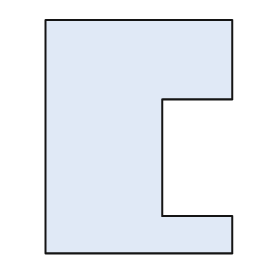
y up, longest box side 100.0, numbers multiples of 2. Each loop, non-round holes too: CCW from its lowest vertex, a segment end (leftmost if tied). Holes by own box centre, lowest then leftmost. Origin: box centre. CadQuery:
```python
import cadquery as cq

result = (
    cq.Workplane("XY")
    .moveTo(-40.0, -50.0)
    .lineTo(40.0, -50.0)
    .lineTo(40.0, -34.0)
    .lineTo(10.0, -34.0)
    .lineTo(10.0, 16.0)
    .lineTo(40.0, 16.0)
    .lineTo(40.0, 50.0)
    .lineTo(-40.0, 50.0)
    .close()
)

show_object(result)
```